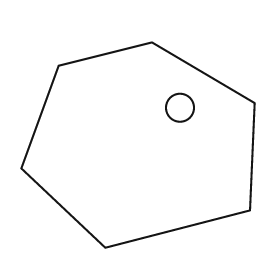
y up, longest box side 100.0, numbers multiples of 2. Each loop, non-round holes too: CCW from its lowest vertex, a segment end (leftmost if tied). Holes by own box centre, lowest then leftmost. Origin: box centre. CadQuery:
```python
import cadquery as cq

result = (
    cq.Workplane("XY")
    .moveTo(-14.0, -44.0)
    .lineTo(48.0, -28.0)
    .lineTo(50.0, 18.0)
    .lineTo(6.0, 44.0)
    .lineTo(-34.0, 34.0)
    .lineTo(-50.0, -10.0)
    .close()
    .moveTo(18.0, 16.0)
    .circle(6.0)
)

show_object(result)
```